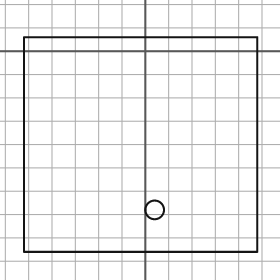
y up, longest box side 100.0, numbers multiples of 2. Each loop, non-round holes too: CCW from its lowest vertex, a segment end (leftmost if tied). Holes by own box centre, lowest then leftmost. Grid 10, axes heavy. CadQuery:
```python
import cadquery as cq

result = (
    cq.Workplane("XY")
    .moveTo(-52.0, -86.0)
    .lineTo(48.0, -86.0)
    .lineTo(48.0, 6.0)
    .lineTo(-52.0, 6.0)
    .close()
    .moveTo(4.0, -68.0)
    .circle(4.0)
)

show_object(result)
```